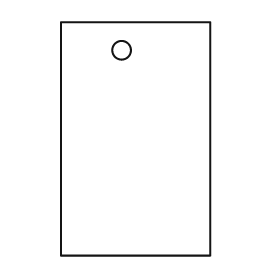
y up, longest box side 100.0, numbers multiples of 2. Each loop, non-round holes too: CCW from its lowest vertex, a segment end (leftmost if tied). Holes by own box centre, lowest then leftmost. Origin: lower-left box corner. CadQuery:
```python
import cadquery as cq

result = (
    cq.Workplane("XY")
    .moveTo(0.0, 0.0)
    .lineTo(64.0, 0.0)
    .lineTo(64.0, 100.0)
    .lineTo(0.0, 100.0)
    .close()
    .moveTo(26.0, 88.0)
    .circle(4.0)
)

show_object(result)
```